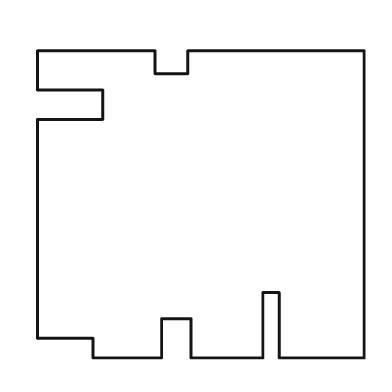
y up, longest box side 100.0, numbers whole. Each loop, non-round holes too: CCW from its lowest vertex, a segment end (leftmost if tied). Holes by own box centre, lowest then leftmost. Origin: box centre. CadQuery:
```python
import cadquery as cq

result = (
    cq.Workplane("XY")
    .moveTo(-33.0, -47.0)
    .lineTo(-12.0, -47.0)
    .lineTo(-12.0, -35.0)
    .lineTo(-3.0, -35.0)
    .lineTo(-3.0, -47.0)
    .lineTo(19.0, -47.0)
    .lineTo(19.0, -27.0)
    .lineTo(24.0, -27.0)
    .lineTo(24.0, -47.0)
    .lineTo(50.0, -47.0)
    .lineTo(50.0, 47.0)
    .lineTo(-4.0, 47.0)
    .lineTo(-4.0, 40.0)
    .lineTo(-14.0, 40.0)
    .lineTo(-14.0, 47.0)
    .lineTo(-50.0, 47.0)
    .lineTo(-50.0, 35.0)
    .lineTo(-30.0, 35.0)
    .lineTo(-30.0, 26.0)
    .lineTo(-50.0, 26.0)
    .lineTo(-50.0, -41.0)
    .lineTo(-33.0, -41.0)
    .close()
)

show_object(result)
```